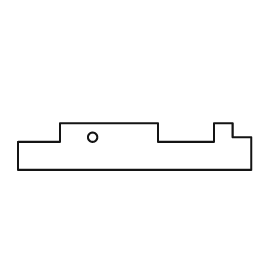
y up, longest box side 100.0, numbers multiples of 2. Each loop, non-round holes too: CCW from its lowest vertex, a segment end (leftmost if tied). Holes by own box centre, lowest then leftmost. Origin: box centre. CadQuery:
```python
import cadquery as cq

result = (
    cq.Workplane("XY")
    .moveTo(-50.0, -10.0)
    .lineTo(50.0, -10.0)
    .lineTo(50.0, 4.0)
    .lineTo(42.0, 4.0)
    .lineTo(42.0, 10.0)
    .lineTo(34.0, 10.0)
    .lineTo(34.0, 2.0)
    .lineTo(10.0, 2.0)
    .lineTo(10.0, 10.0)
    .lineTo(-32.0, 10.0)
    .lineTo(-32.0, 2.0)
    .lineTo(-50.0, 2.0)
    .close()
    .moveTo(-18.0, 4.0)
    .circle(2.0)
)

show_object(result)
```